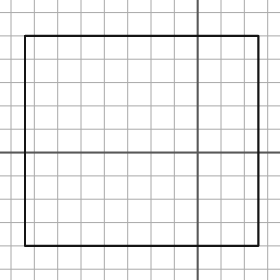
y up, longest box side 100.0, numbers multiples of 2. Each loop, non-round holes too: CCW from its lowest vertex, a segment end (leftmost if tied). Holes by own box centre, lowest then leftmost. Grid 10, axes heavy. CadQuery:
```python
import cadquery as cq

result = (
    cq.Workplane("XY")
    .moveTo(-74.0, -40.0)
    .lineTo(26.0, -40.0)
    .lineTo(26.0, 50.0)
    .lineTo(-74.0, 50.0)
    .close()
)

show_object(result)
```